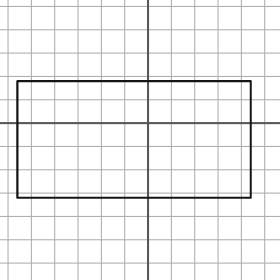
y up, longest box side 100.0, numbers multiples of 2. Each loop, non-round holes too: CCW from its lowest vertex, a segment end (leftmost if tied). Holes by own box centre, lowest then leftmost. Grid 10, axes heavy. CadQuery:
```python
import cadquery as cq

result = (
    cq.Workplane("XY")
    .moveTo(-56.0, -32.0)
    .lineTo(44.0, -32.0)
    .lineTo(44.0, 18.0)
    .lineTo(-56.0, 18.0)
    .close()
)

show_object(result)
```